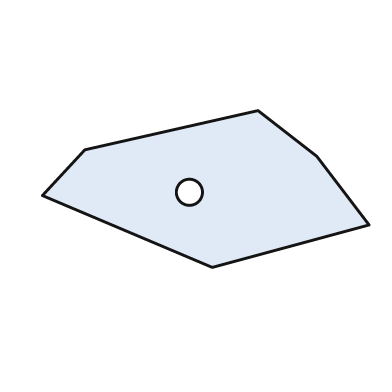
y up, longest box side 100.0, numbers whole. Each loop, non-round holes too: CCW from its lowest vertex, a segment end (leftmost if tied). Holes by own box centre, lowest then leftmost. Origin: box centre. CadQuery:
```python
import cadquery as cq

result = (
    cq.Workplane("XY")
    .moveTo(2.0, -24.0)
    .lineTo(50.0, -11.0)
    .lineTo(34.0, 10.0)
    .lineTo(16.0, 24.0)
    .lineTo(-37.0, 12.0)
    .lineTo(-50.0, -2.0)
    .close()
    .moveTo(-5.0, -1.0)
    .circle(4.0)
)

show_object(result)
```